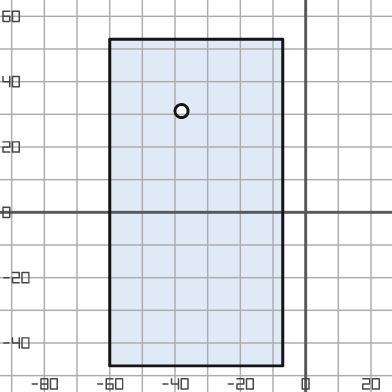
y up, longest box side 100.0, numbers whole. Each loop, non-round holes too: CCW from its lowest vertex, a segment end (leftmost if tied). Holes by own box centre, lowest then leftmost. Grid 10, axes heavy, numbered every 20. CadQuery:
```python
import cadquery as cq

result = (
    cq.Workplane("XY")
    .moveTo(-60.0, -47.0)
    .lineTo(-7.0, -47.0)
    .lineTo(-7.0, 53.0)
    .lineTo(-60.0, 53.0)
    .close()
    .moveTo(-38.0, 31.0)
    .circle(2.0)
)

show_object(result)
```